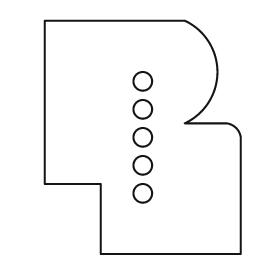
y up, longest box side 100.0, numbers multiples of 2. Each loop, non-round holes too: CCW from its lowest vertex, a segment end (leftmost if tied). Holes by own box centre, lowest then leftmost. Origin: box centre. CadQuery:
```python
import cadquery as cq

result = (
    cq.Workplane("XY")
    .moveTo(-18.0, -50.0)
    .lineTo(42.0, -50.0)
    .lineTo(42.0, 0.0)
    .threePointArc((40.0, 4.0), (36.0, 6.0))
    .lineTo(18.0, 6.0)
    .threePointArc((32.0, 28.0), (18.0, 50.0))
    .lineTo(-42.0, 50.0)
    .lineTo(-42.0, -20.0)
    .lineTo(-18.0, -20.0)
    .close()
    .moveTo(0.0, -24.0)
    .circle(4.0)
    .moveTo(0.0, -12.0)
    .circle(4.0)
    .moveTo(0.0, 0.0)
    .circle(4.0)
    .moveTo(0.0, 12.0)
    .circle(4.0)
    .moveTo(0.0, 24.0)
    .circle(4.0)
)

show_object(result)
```